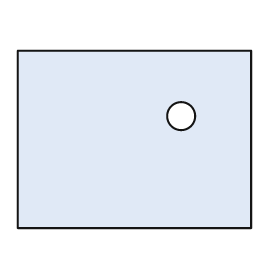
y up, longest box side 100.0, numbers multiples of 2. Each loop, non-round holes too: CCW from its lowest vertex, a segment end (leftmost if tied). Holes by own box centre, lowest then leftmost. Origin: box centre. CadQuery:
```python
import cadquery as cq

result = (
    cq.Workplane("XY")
    .moveTo(-50.0, -38.0)
    .lineTo(50.0, -38.0)
    .lineTo(50.0, 38.0)
    .lineTo(-50.0, 38.0)
    .close()
    .moveTo(20.0, 10.0)
    .circle(6.0)
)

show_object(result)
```